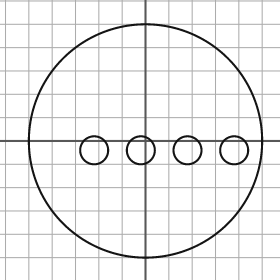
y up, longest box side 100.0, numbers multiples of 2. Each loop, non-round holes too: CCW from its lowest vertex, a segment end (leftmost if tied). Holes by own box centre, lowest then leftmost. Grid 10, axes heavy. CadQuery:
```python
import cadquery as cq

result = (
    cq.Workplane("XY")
    .moveTo(0.0, 0.0)
    .circle(50.0)
    .moveTo(-22.0, -4.0)
    .circle(6.0)
    .moveTo(-2.0, -4.0)
    .circle(6.0)
    .moveTo(18.0, -4.0)
    .circle(6.0)
    .moveTo(38.0, -4.0)
    .circle(6.0)
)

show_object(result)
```